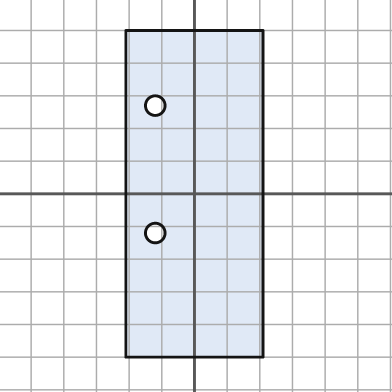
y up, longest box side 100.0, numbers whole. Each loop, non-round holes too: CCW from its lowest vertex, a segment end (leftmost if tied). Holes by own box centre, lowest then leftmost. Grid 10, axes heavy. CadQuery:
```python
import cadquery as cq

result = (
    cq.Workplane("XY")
    .moveTo(-21.0, -50.0)
    .lineTo(21.0, -50.0)
    .lineTo(21.0, 50.0)
    .lineTo(-21.0, 50.0)
    .close()
    .moveTo(-12.0, -12.0)
    .circle(3.0)
    .moveTo(-12.0, 27.0)
    .circle(3.0)
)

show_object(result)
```